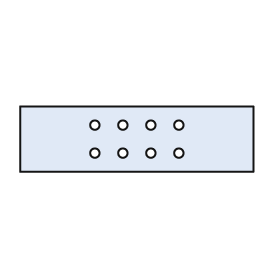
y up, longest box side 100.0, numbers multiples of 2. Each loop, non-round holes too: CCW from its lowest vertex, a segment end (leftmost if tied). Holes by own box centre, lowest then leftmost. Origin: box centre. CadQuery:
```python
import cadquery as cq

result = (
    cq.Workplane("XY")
    .moveTo(-50.0, -14.0)
    .lineTo(50.0, -14.0)
    .lineTo(50.0, 14.0)
    .lineTo(-50.0, 14.0)
    .close()
    .moveTo(-18.0, -6.0)
    .circle(2.0)
    .moveTo(-6.0, -6.0)
    .circle(2.0)
    .moveTo(6.0, -6.0)
    .circle(2.0)
    .moveTo(18.0, -6.0)
    .circle(2.0)
    .moveTo(-18.0, 6.0)
    .circle(2.0)
    .moveTo(-6.0, 6.0)
    .circle(2.0)
    .moveTo(6.0, 6.0)
    .circle(2.0)
    .moveTo(18.0, 6.0)
    .circle(2.0)
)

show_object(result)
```